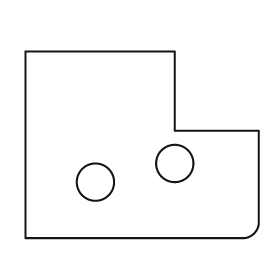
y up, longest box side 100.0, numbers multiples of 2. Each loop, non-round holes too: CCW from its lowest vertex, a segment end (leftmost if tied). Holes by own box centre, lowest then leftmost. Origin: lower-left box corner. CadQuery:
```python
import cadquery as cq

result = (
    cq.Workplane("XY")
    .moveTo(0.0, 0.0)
    .lineTo(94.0, 0.0)
    .threePointArc((98.0, 2.0), (100.0, 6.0))
    .lineTo(100.0, 46.0)
    .lineTo(64.0, 46.0)
    .lineTo(64.0, 80.0)
    .lineTo(0.0, 80.0)
    .close()
    .moveTo(30.0, 24.0)
    .circle(8.0)
    .moveTo(64.0, 32.0)
    .circle(8.0)
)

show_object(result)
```